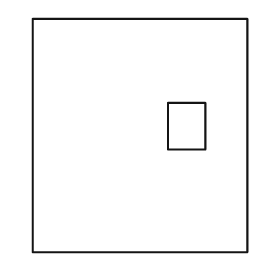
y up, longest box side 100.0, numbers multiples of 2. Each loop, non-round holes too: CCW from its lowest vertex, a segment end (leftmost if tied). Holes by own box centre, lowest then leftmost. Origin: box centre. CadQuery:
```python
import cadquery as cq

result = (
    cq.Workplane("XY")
    .moveTo(-46.0, -50.0)
    .lineTo(46.0, -50.0)
    .lineTo(46.0, 50.0)
    .lineTo(-46.0, 50.0)
    .close()
    .moveTo(12.0, -6.0)
    .lineTo(28.0, -6.0)
    .lineTo(28.0, 14.0)
    .lineTo(12.0, 14.0)
    .close()
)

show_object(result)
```